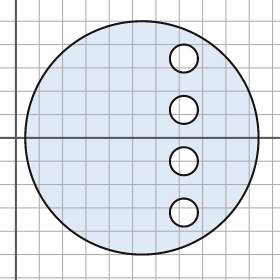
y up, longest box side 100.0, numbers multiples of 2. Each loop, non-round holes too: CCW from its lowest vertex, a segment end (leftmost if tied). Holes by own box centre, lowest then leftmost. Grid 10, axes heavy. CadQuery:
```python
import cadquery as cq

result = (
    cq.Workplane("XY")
    .moveTo(54.0, 0.0)
    .circle(50.0)
    .moveTo(72.0, -32.0)
    .circle(6.0)
    .moveTo(72.0, -10.0)
    .circle(6.0)
    .moveTo(72.0, 12.0)
    .circle(6.0)
    .moveTo(72.0, 34.0)
    .circle(6.0)
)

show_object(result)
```